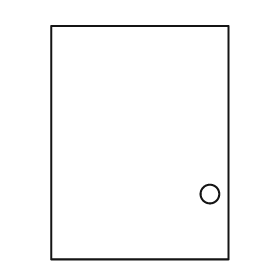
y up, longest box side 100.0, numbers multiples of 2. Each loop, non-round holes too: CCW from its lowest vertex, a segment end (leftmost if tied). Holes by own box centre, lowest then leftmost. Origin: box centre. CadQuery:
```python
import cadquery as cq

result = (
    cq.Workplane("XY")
    .moveTo(-38.0, -50.0)
    .lineTo(38.0, -50.0)
    .lineTo(38.0, 50.0)
    .lineTo(-38.0, 50.0)
    .close()
    .moveTo(30.0, -22.0)
    .circle(4.0)
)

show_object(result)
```